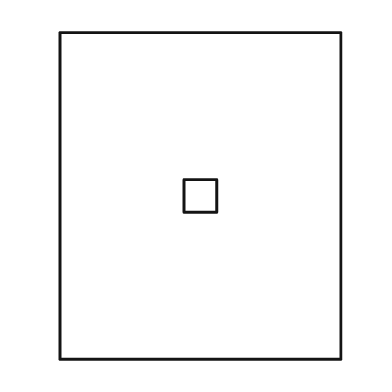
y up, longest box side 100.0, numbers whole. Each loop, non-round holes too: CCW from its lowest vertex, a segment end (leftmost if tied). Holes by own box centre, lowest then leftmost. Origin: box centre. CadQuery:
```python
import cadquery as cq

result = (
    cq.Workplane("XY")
    .moveTo(-43.0, -50.0)
    .lineTo(43.0, -50.0)
    .lineTo(43.0, 50.0)
    .lineTo(-43.0, 50.0)
    .close()
    .moveTo(-5.0, -5.0)
    .lineTo(5.0, -5.0)
    .lineTo(5.0, 5.0)
    .lineTo(-5.0, 5.0)
    .close()
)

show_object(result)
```